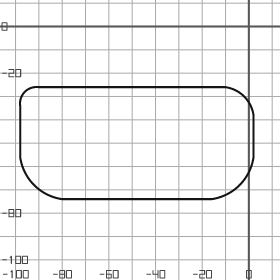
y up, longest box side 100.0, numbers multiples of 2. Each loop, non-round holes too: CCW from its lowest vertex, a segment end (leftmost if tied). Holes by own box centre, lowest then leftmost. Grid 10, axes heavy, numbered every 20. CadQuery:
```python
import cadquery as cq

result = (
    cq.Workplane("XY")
    .moveTo(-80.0, -74.0)
    .lineTo(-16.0, -74.0)
    .threePointArc((-4.0, -68.0), (2.0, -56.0))
    .lineTo(2.0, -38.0)
    .threePointArc((-2.0, -30.0), (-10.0, -26.0))
    .lineTo(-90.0, -26.0)
    .threePointArc((-96.0, -28.0), (-98.0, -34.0))
    .lineTo(-98.0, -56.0)
    .threePointArc((-92.0, -68.0), (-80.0, -74.0))
    .close()
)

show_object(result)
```